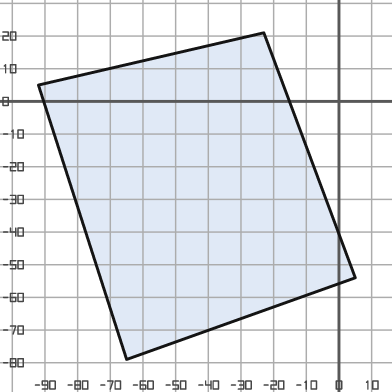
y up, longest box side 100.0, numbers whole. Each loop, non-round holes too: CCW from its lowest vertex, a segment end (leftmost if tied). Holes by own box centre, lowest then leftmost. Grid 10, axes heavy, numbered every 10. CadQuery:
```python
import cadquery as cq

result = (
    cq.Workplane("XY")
    .moveTo(-65.0, -79.0)
    .lineTo(5.0, -54.0)
    .lineTo(-23.0, 21.0)
    .lineTo(-92.0, 5.0)
    .close()
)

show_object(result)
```